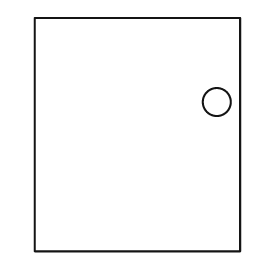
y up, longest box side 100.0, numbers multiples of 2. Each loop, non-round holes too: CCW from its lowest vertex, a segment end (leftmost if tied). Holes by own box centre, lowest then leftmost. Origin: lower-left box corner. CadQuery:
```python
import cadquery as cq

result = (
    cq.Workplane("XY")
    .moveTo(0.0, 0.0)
    .lineTo(88.0, 0.0)
    .lineTo(88.0, 100.0)
    .lineTo(0.0, 100.0)
    .close()
    .moveTo(78.0, 64.0)
    .circle(6.0)
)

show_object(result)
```